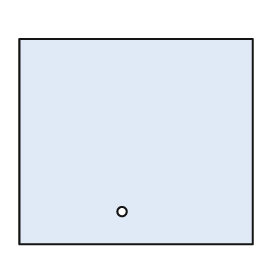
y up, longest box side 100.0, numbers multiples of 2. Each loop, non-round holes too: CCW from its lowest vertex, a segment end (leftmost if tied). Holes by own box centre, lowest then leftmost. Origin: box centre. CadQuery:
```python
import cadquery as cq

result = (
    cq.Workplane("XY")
    .moveTo(-50.0, -44.0)
    .lineTo(50.0, -44.0)
    .lineTo(50.0, 44.0)
    .lineTo(-50.0, 44.0)
    .close()
    .moveTo(-6.0, -30.0)
    .circle(2.0)
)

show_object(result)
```